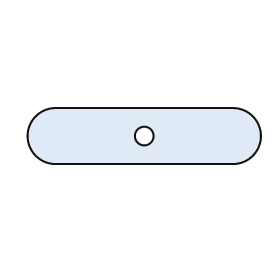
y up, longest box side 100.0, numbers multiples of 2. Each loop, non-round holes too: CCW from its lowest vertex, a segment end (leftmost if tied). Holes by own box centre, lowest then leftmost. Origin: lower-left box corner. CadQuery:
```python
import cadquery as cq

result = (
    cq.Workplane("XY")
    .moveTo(12.0, 0.0)
    .lineTo(88.0, 0.0)
    .threePointArc((100.0, 12.0), (88.0, 24.0))
    .lineTo(12.0, 24.0)
    .threePointArc((0.0, 12.0), (12.0, 0.0))
    .close()
    .moveTo(50.0, 12.0)
    .circle(4.0)
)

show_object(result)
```